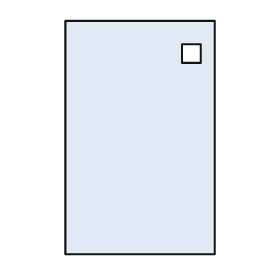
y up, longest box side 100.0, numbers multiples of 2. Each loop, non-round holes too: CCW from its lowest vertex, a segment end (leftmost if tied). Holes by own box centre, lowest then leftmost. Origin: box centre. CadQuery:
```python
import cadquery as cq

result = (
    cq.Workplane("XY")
    .moveTo(-32.0, -50.0)
    .lineTo(32.0, -50.0)
    .lineTo(32.0, 50.0)
    .lineTo(-32.0, 50.0)
    .close()
    .moveTo(18.0, 32.0)
    .lineTo(26.0, 32.0)
    .lineTo(26.0, 40.0)
    .lineTo(18.0, 40.0)
    .close()
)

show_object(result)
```